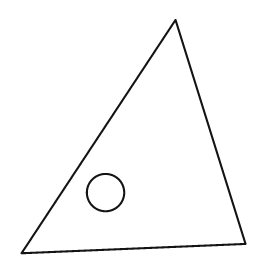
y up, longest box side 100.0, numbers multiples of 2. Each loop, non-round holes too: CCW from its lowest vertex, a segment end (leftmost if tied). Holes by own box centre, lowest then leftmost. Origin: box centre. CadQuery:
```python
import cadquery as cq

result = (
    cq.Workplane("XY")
    .moveTo(-48.0, -50.0)
    .lineTo(48.0, -46.0)
    .lineTo(18.0, 50.0)
    .close()
    .moveTo(-12.0, -24.0)
    .circle(8.0)
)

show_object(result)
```